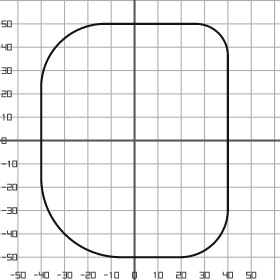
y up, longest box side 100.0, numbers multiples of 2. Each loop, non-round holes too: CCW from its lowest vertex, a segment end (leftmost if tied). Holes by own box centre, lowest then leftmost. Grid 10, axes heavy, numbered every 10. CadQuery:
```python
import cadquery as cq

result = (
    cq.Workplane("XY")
    .moveTo(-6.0, -50.0)
    .lineTo(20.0, -50.0)
    .threePointArc((34.0, -44.0), (40.0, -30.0))
    .lineTo(40.0, 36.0)
    .threePointArc((36.0, 46.0), (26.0, 50.0))
    .lineTo(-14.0, 50.0)
    .threePointArc((-32.0, 42.0), (-40.0, 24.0))
    .lineTo(-40.0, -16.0)
    .threePointArc((-30.0, -40.0), (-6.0, -50.0))
    .close()
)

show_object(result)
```